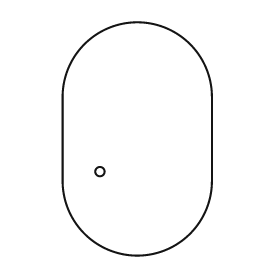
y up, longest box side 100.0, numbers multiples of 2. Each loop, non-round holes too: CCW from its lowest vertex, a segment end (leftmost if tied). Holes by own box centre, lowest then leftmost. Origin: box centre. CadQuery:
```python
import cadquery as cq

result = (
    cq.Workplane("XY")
    .moveTo(-32.0, -18.0)
    .threePointArc((0.0, -50.0), (32.0, -18.0))
    .lineTo(32.0, 18.0)
    .threePointArc((0.0, 50.0), (-32.0, 18.0))
    .close()
    .moveTo(-16.0, -14.0)
    .circle(2.0)
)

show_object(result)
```